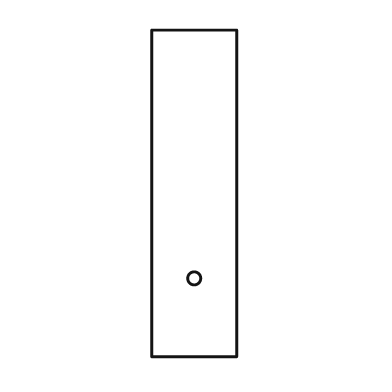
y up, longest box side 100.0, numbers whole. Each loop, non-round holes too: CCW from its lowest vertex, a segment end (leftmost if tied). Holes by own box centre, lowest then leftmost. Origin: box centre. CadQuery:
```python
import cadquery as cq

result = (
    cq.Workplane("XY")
    .moveTo(-13.0, -50.0)
    .lineTo(13.0, -50.0)
    .lineTo(13.0, 50.0)
    .lineTo(-13.0, 50.0)
    .close()
    .moveTo(0.0, -26.0)
    .circle(2.0)
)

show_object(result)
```